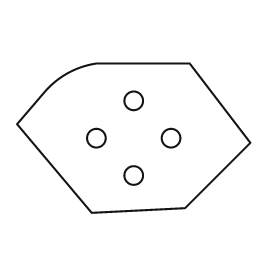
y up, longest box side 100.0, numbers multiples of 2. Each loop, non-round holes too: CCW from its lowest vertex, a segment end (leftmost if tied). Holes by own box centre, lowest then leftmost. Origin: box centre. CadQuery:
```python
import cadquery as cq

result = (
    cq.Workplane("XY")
    .moveTo(-18.0, -32.0)
    .lineTo(22.0, -30.0)
    .lineTo(50.0, -2.0)
    .lineTo(24.0, 32.0)
    .lineTo(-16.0, 32.0)
    .threePointArc((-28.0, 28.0), (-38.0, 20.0))
    .lineTo(-50.0, 6.0)
    .close()
    .moveTo(0.0, -16.0)
    .circle(4.0)
    .moveTo(-16.0, 0.0)
    .circle(4.0)
    .moveTo(16.0, 0.0)
    .circle(4.0)
    .moveTo(0.0, 16.0)
    .circle(4.0)
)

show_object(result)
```